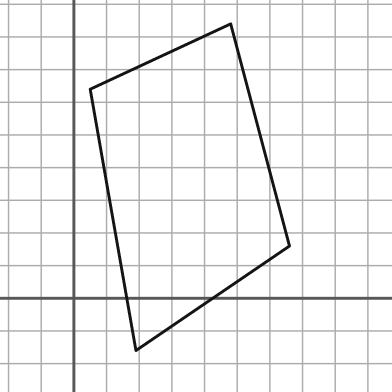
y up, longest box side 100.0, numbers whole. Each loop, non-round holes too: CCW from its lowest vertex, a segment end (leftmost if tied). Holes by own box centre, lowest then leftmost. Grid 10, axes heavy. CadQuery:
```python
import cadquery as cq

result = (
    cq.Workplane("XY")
    .moveTo(19.0, -16.0)
    .lineTo(66.0, 16.0)
    .lineTo(48.0, 84.0)
    .lineTo(5.0, 64.0)
    .close()
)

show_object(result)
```